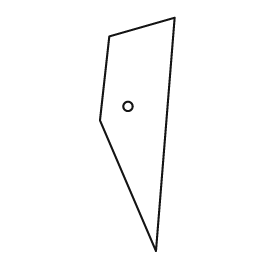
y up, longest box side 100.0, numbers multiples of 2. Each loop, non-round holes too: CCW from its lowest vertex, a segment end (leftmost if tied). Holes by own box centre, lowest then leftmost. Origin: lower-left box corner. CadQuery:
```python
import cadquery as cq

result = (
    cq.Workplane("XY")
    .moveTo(24.0, 0.0)
    .lineTo(32.0, 100.0)
    .lineTo(4.0, 92.0)
    .lineTo(0.0, 56.0)
    .close()
    .moveTo(12.0, 62.0)
    .circle(2.0)
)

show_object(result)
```